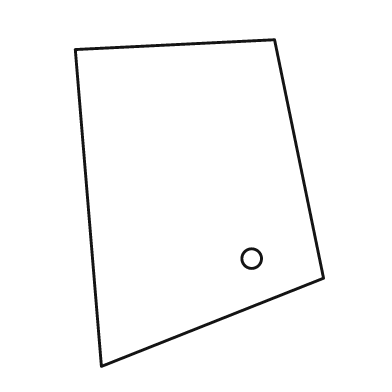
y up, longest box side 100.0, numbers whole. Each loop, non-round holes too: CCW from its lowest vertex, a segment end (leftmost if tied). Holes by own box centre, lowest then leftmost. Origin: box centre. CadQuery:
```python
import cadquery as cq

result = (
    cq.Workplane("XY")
    .moveTo(-30.0, -50.0)
    .lineTo(38.0, -23.0)
    .lineTo(23.0, 50.0)
    .lineTo(-38.0, 47.0)
    .close()
    .moveTo(16.0, -17.0)
    .circle(3.0)
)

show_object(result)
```